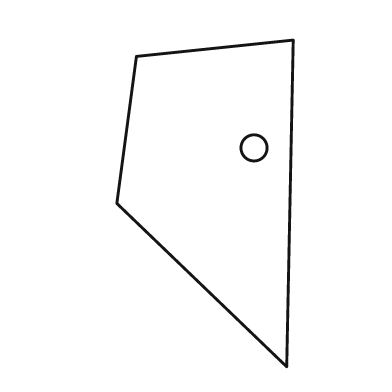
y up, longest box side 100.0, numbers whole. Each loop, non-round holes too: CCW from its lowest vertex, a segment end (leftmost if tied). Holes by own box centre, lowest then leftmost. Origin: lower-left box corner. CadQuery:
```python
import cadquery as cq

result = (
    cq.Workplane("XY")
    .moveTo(52.0, 0.0)
    .lineTo(54.0, 100.0)
    .lineTo(6.0, 95.0)
    .lineTo(0.0, 50.0)
    .close()
    .moveTo(42.0, 67.0)
    .circle(4.0)
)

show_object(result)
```